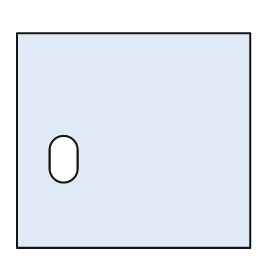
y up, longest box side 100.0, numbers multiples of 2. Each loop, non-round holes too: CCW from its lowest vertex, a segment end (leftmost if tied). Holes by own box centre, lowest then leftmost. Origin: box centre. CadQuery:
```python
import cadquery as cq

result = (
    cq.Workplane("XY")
    .moveTo(-50.0, -46.0)
    .lineTo(50.0, -46.0)
    .lineTo(50.0, 46.0)
    .lineTo(-50.0, 46.0)
    .close()
    .moveTo(-36.0, -12.0)
    .threePointArc((-30.0, -18.0), (-24.0, -12.0))
    .lineTo(-24.0, -4.0)
    .threePointArc((-30.0, 2.0), (-36.0, -4.0))
    .close()
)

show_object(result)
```